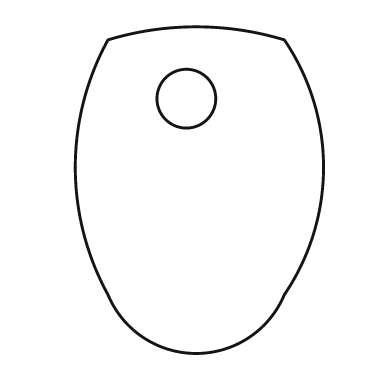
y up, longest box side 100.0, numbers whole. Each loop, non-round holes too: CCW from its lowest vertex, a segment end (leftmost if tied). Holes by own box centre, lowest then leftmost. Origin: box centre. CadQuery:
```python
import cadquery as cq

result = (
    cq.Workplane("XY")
    .moveTo(-28.0, -32.0)
    .threePointArc((-1.0, -50.0), (26.0, -32.0))
    .threePointArc((38.0, 7.0), (26.0, 46.0))
    .threePointArc((-1.0, 50.0), (-28.0, 46.0))
    .threePointArc((-38.0, 7.0), (-28.0, -32.0))
    .close()
    .moveTo(-4.0, 28.0)
    .circle(9.0)
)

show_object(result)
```